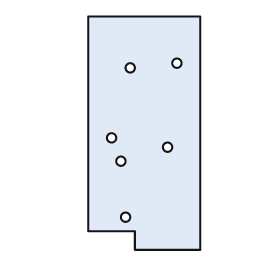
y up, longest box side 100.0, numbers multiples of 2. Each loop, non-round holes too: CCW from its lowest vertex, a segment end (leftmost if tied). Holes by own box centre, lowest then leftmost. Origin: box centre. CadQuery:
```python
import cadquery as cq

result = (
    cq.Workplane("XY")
    .moveTo(-4.0, -50.0)
    .lineTo(24.0, -50.0)
    .lineTo(24.0, 50.0)
    .lineTo(-24.0, 50.0)
    .lineTo(-24.0, -42.0)
    .lineTo(-4.0, -42.0)
    .close()
    .moveTo(-8.0, -36.0)
    .circle(2.0)
    .moveTo(-10.0, -12.0)
    .circle(2.0)
    .moveTo(10.0, -6.0)
    .circle(2.0)
    .moveTo(-14.0, -2.0)
    .circle(2.0)
    .moveTo(-6.0, 28.0)
    .circle(2.0)
    .moveTo(14.0, 30.0)
    .circle(2.0)
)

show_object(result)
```